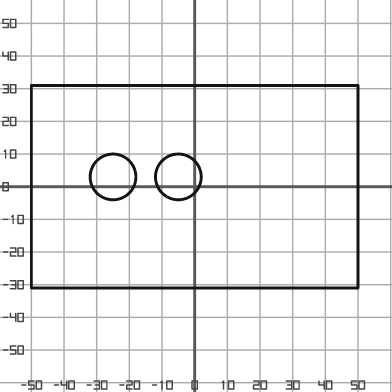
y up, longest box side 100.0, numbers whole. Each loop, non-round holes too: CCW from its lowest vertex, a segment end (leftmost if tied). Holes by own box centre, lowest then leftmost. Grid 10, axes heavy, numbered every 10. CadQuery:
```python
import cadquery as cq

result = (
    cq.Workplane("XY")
    .moveTo(-50.0, -31.0)
    .lineTo(50.0, -31.0)
    .lineTo(50.0, 31.0)
    .lineTo(-50.0, 31.0)
    .close()
    .moveTo(-25.0, 3.0)
    .circle(7.0)
    .moveTo(-5.0, 3.0)
    .circle(7.0)
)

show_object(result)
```